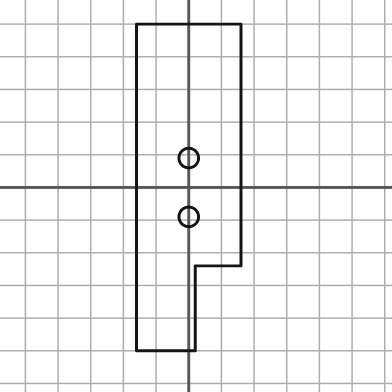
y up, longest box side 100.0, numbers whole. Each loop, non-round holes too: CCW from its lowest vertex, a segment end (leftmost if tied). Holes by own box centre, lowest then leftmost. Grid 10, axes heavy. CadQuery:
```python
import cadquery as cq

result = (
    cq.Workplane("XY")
    .moveTo(-16.0, -50.0)
    .lineTo(2.0, -50.0)
    .lineTo(2.0, -24.0)
    .lineTo(16.0, -24.0)
    .lineTo(16.0, 50.0)
    .lineTo(-16.0, 50.0)
    .close()
    .moveTo(0.0, -9.0)
    .circle(3.0)
    .moveTo(0.0, 9.0)
    .circle(3.0)
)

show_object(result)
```